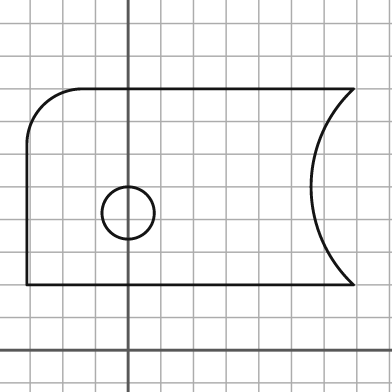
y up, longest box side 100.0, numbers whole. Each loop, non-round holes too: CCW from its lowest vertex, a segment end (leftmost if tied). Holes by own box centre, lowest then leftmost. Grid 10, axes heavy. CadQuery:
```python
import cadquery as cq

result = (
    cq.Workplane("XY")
    .moveTo(-31.0, 20.0)
    .lineTo(69.0, 20.0)
    .threePointArc((56.0, 50.0), (69.0, 80.0))
    .lineTo(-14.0, 80.0)
    .threePointArc((-26.0, 75.0), (-31.0, 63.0))
    .close()
    .moveTo(0.0, 42.0)
    .circle(8.0)
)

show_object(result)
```